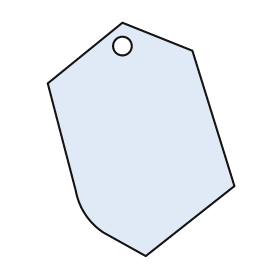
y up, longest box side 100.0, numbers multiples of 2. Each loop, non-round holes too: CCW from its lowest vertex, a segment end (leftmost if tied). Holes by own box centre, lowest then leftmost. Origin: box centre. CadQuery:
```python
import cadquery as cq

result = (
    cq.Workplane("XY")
    .moveTo(2.0, -50.0)
    .lineTo(40.0, -20.0)
    .lineTo(22.0, 38.0)
    .lineTo(-8.0, 50.0)
    .lineTo(-40.0, 24.0)
    .lineTo(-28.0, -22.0)
    .threePointArc((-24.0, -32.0), (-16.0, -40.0))
    .close()
    .moveTo(-8.0, 40.0)
    .circle(4.0)
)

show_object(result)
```